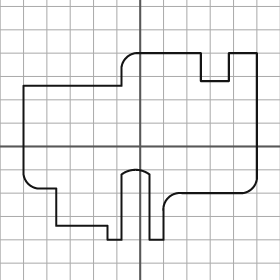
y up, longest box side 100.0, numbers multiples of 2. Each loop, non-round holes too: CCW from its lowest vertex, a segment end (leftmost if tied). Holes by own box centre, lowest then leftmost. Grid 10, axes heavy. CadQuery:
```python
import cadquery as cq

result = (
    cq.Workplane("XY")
    .moveTo(-14.0, -40.0)
    .lineTo(-8.0, -40.0)
    .lineTo(-8.0, -12.0)
    .threePointArc((-2.0, -10.0), (4.0, -12.0))
    .lineTo(4.0, -40.0)
    .lineTo(10.0, -40.0)
    .lineTo(10.0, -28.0)
    .threePointArc((12.0, -22.0), (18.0, -20.0))
    .lineTo(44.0, -20.0)
    .threePointArc((48.0, -18.0), (50.0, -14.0))
    .lineTo(50.0, 40.0)
    .lineTo(38.0, 40.0)
    .lineTo(38.0, 28.0)
    .lineTo(26.0, 28.0)
    .lineTo(26.0, 40.0)
    .lineTo(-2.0, 40.0)
    .threePointArc((-6.0, 38.0), (-8.0, 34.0))
    .lineTo(-8.0, 26.0)
    .lineTo(-50.0, 26.0)
    .lineTo(-50.0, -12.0)
    .threePointArc((-48.0, -16.0), (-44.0, -18.0))
    .lineTo(-36.0, -18.0)
    .lineTo(-36.0, -34.0)
    .lineTo(-14.0, -34.0)
    .close()
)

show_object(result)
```